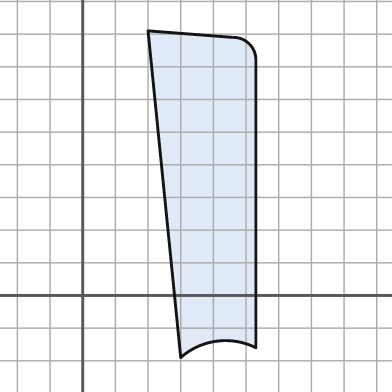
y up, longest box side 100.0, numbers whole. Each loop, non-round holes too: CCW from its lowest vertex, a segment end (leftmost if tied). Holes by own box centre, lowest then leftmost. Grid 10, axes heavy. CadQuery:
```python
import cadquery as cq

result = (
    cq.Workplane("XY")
    .moveTo(30.0, -19.0)
    .threePointArc((41.0, -14.0), (53.0, -16.0))
    .lineTo(53.0, 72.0)
    .threePointArc((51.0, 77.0), (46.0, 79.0))
    .lineTo(20.0, 81.0)
    .close()
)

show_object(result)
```